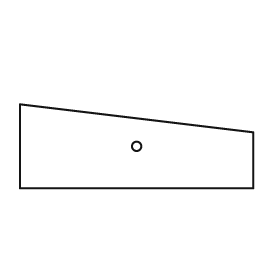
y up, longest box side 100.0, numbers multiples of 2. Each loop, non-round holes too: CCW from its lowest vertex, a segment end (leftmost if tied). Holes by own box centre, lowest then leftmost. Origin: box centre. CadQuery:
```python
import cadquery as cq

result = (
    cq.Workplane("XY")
    .moveTo(-50.0, -18.0)
    .lineTo(50.0, -18.0)
    .lineTo(50.0, 6.0)
    .lineTo(-50.0, 18.0)
    .close()
    .moveTo(0.0, 0.0)
    .circle(2.0)
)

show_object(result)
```